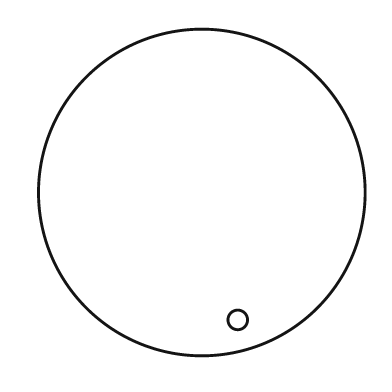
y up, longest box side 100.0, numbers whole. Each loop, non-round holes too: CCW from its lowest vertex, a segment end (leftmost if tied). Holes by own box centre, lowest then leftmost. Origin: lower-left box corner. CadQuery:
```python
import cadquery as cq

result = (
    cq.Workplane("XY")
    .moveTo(50.0, 50.0)
    .circle(50.0)
    .moveTo(61.0, 11.0)
    .circle(3.0)
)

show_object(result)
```